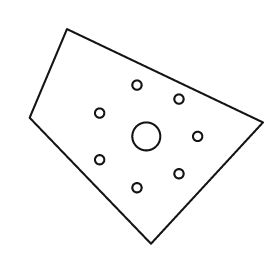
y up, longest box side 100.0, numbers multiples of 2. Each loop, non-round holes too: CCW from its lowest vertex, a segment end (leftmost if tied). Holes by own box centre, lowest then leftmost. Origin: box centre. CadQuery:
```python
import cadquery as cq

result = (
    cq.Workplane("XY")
    .moveTo(2.0, -46.0)
    .lineTo(50.0, 6.0)
    .lineTo(-34.0, 46.0)
    .lineTo(-50.0, 8.0)
    .close()
    .moveTo(-4.0, -22.0)
    .circle(2.0)
    .moveTo(14.0, -16.0)
    .circle(2.0)
    .moveTo(-20.0, -10.0)
    .circle(2.0)
    .moveTo(0.0, 0.0)
    .circle(6.0)
    .moveTo(22.0, 0.0)
    .circle(2.0)
    .moveTo(-20.0, 10.0)
    .circle(2.0)
    .moveTo(14.0, 16.0)
    .circle(2.0)
    .moveTo(-4.0, 22.0)
    .circle(2.0)
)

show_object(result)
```